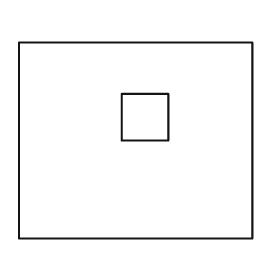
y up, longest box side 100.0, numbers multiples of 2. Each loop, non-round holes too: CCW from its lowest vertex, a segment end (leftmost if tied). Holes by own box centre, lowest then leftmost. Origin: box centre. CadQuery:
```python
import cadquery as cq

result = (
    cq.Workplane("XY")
    .moveTo(-50.0, -42.0)
    .lineTo(50.0, -42.0)
    .lineTo(50.0, 42.0)
    .lineTo(-50.0, 42.0)
    .close()
    .moveTo(-6.0, 0.0)
    .lineTo(14.0, 0.0)
    .lineTo(14.0, 20.0)
    .lineTo(-6.0, 20.0)
    .close()
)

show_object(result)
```